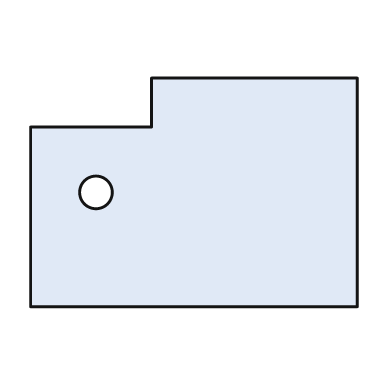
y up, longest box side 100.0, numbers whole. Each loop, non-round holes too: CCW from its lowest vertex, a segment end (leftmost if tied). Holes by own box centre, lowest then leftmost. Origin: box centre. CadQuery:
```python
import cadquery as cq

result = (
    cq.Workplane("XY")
    .moveTo(-50.0, -35.0)
    .lineTo(50.0, -35.0)
    .lineTo(50.0, 35.0)
    .lineTo(-13.0, 35.0)
    .lineTo(-13.0, 20.0)
    .lineTo(-50.0, 20.0)
    .close()
    .moveTo(-30.0, 0.0)
    .circle(5.0)
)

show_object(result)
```